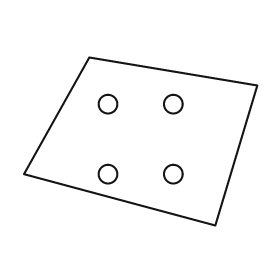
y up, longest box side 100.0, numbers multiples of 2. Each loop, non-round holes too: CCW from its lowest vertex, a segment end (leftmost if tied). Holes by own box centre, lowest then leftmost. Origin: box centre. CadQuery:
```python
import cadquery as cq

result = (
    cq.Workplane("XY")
    .moveTo(32.0, -36.0)
    .lineTo(50.0, 24.0)
    .lineTo(-22.0, 36.0)
    .lineTo(-50.0, -14.0)
    .close()
    .moveTo(-14.0, -14.0)
    .circle(4.0)
    .moveTo(14.0, -14.0)
    .circle(4.0)
    .moveTo(-14.0, 16.0)
    .circle(4.0)
    .moveTo(14.0, 16.0)
    .circle(4.0)
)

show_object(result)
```